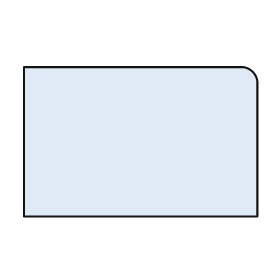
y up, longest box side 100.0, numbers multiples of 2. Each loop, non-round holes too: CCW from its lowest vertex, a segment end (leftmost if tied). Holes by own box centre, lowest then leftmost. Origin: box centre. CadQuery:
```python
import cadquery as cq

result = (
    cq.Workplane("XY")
    .moveTo(-50.0, -32.0)
    .lineTo(50.0, -32.0)
    .lineTo(50.0, 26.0)
    .threePointArc((48.0, 30.0), (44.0, 32.0))
    .lineTo(-50.0, 32.0)
    .close()
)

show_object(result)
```